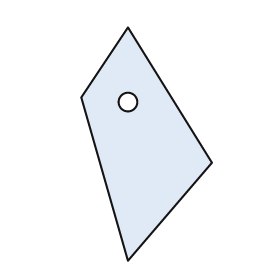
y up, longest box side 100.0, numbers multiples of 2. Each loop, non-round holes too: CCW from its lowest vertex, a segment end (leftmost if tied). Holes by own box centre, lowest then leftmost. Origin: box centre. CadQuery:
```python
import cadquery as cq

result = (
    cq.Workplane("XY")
    .moveTo(-8.0, -50.0)
    .lineTo(28.0, -8.0)
    .lineTo(-8.0, 50.0)
    .lineTo(-28.0, 20.0)
    .close()
    .moveTo(-8.0, 18.0)
    .circle(4.0)
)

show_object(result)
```